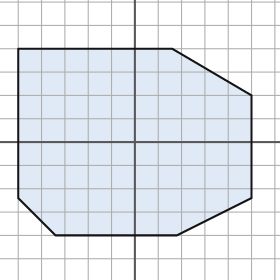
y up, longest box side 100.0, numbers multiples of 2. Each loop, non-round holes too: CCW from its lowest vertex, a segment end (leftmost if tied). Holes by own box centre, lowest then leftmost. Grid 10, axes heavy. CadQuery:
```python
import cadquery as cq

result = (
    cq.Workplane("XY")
    .moveTo(-34.0, -40.0)
    .lineTo(18.0, -40.0)
    .lineTo(50.0, -24.0)
    .lineTo(50.0, 20.0)
    .lineTo(16.0, 40.0)
    .lineTo(-50.0, 40.0)
    .lineTo(-50.0, -24.0)
    .close()
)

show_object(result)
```